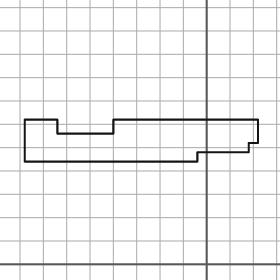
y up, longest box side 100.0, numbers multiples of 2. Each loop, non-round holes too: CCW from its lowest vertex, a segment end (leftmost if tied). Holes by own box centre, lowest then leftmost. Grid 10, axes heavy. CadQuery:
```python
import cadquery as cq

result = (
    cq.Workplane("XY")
    .moveTo(-78.0, 44.0)
    .lineTo(-4.0, 44.0)
    .lineTo(-4.0, 48.0)
    .lineTo(18.0, 48.0)
    .lineTo(18.0, 52.0)
    .lineTo(22.0, 52.0)
    .lineTo(22.0, 62.0)
    .lineTo(-40.0, 62.0)
    .lineTo(-40.0, 56.0)
    .lineTo(-64.0, 56.0)
    .lineTo(-64.0, 62.0)
    .lineTo(-78.0, 62.0)
    .close()
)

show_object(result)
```